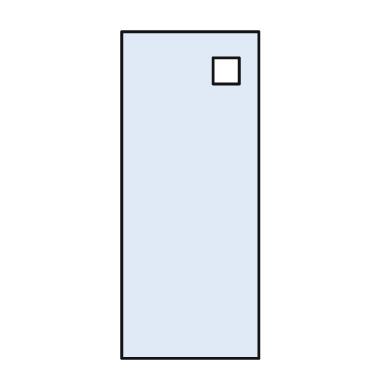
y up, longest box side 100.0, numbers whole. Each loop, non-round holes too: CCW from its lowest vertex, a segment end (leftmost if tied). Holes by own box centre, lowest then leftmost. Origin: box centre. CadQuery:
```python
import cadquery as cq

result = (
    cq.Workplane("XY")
    .moveTo(-21.0, -50.0)
    .lineTo(21.0, -50.0)
    .lineTo(21.0, 50.0)
    .lineTo(-21.0, 50.0)
    .close()
    .moveTo(7.0, 34.0)
    .lineTo(15.0, 34.0)
    .lineTo(15.0, 42.0)
    .lineTo(7.0, 42.0)
    .close()
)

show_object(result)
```